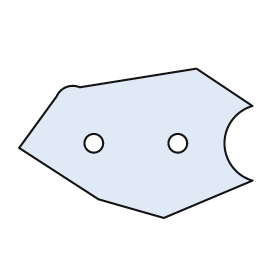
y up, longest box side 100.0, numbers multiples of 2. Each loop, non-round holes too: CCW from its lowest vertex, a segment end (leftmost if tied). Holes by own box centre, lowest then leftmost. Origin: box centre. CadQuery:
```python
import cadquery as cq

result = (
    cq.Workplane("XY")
    .moveTo(12.0, -32.0)
    .lineTo(50.0, -16.0)
    .threePointArc((38.0, 0.0), (50.0, 16.0))
    .lineTo(26.0, 32.0)
    .lineTo(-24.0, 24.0)
    .threePointArc((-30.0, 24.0), (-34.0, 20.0))
    .lineTo(-50.0, -2.0)
    .lineTo(-16.0, -24.0)
    .close()
    .moveTo(-18.0, 0.0)
    .circle(4.0)
    .moveTo(18.0, 0.0)
    .circle(4.0)
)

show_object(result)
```